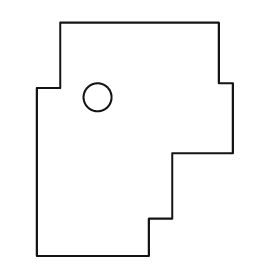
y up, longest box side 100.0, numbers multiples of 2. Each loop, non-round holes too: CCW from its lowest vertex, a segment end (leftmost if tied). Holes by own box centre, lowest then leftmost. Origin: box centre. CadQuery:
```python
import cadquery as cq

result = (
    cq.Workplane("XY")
    .moveTo(-42.0, -50.0)
    .lineTo(6.0, -50.0)
    .lineTo(6.0, -34.0)
    .lineTo(16.0, -34.0)
    .lineTo(16.0, -6.0)
    .lineTo(42.0, -6.0)
    .lineTo(42.0, 24.0)
    .lineTo(36.0, 24.0)
    .lineTo(36.0, 50.0)
    .lineTo(-32.0, 50.0)
    .lineTo(-32.0, 22.0)
    .lineTo(-42.0, 22.0)
    .close()
    .moveTo(-16.0, 18.0)
    .circle(6.0)
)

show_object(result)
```